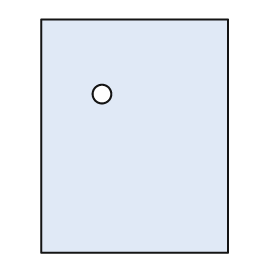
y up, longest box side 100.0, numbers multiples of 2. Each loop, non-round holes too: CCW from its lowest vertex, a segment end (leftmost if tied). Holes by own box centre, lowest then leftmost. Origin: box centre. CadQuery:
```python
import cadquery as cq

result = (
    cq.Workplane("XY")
    .moveTo(-40.0, -50.0)
    .lineTo(40.0, -50.0)
    .lineTo(40.0, 50.0)
    .lineTo(-40.0, 50.0)
    .close()
    .moveTo(-14.0, 18.0)
    .circle(4.0)
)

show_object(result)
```